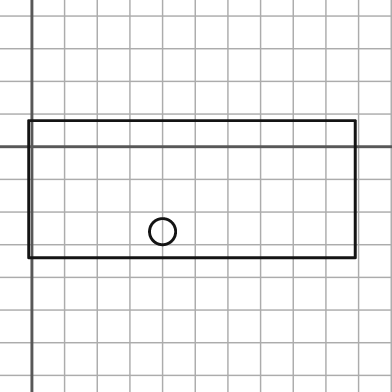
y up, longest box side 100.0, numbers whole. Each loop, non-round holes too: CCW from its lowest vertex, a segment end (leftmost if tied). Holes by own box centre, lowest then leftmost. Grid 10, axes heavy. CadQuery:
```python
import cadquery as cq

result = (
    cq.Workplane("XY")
    .moveTo(-1.0, -34.0)
    .lineTo(99.0, -34.0)
    .lineTo(99.0, 8.0)
    .lineTo(-1.0, 8.0)
    .close()
    .moveTo(40.0, -26.0)
    .circle(4.0)
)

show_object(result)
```